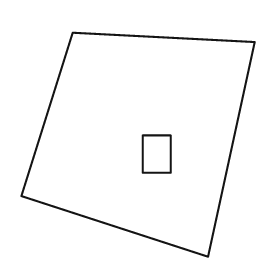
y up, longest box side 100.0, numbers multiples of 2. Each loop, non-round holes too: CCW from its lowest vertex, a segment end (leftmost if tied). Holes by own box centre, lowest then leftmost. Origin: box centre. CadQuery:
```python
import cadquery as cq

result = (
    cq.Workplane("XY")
    .moveTo(30.0, -48.0)
    .lineTo(50.0, 44.0)
    .lineTo(-28.0, 48.0)
    .lineTo(-50.0, -22.0)
    .close()
    .moveTo(2.0, -12.0)
    .lineTo(14.0, -12.0)
    .lineTo(14.0, 4.0)
    .lineTo(2.0, 4.0)
    .close()
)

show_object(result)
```